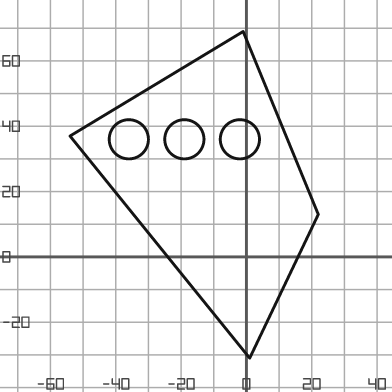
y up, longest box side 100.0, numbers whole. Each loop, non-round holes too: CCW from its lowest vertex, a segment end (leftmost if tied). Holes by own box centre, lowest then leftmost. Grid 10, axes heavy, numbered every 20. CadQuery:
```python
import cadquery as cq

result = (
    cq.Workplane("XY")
    .moveTo(1.0, -31.0)
    .lineTo(22.0, 13.0)
    .lineTo(-1.0, 69.0)
    .lineTo(-54.0, 37.0)
    .close()
    .moveTo(-36.0, 36.0)
    .circle(6.0)
    .moveTo(-19.0, 36.0)
    .circle(6.0)
    .moveTo(-2.0, 36.0)
    .circle(6.0)
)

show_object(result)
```